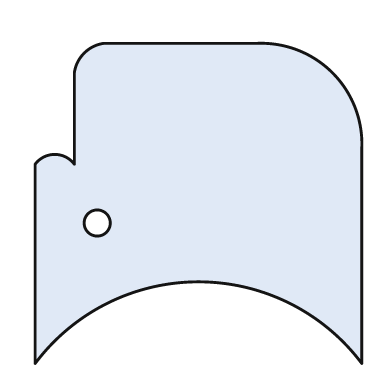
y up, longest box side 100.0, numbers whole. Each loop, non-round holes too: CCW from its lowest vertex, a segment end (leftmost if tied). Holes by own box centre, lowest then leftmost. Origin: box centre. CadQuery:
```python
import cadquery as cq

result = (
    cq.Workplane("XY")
    .moveTo(-50.0, -49.0)
    .threePointArc((0.0, -24.0), (50.0, -49.0))
    .lineTo(50.0, 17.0)
    .threePointArc((41.0, 40.0), (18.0, 49.0))
    .lineTo(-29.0, 49.0)
    .threePointArc((-35.0, 46.0), (-38.0, 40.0))
    .lineTo(-38.0, 12.0)
    .threePointArc((-44.0, 15.0), (-50.0, 12.0))
    .close()
    .moveTo(-31.0, -6.0)
    .circle(4.0)
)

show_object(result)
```